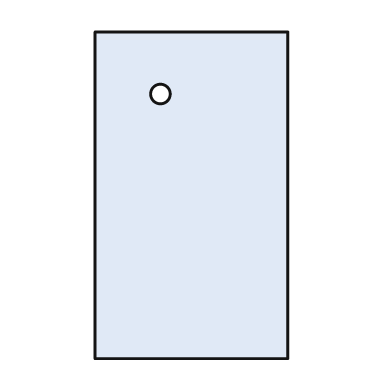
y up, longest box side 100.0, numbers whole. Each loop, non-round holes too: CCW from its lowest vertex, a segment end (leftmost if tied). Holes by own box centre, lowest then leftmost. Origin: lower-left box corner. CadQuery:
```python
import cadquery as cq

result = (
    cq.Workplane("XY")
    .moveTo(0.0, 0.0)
    .lineTo(59.0, 0.0)
    .lineTo(59.0, 100.0)
    .lineTo(0.0, 100.0)
    .close()
    .moveTo(20.0, 81.0)
    .circle(3.0)
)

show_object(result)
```